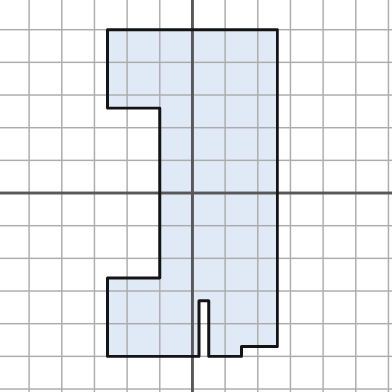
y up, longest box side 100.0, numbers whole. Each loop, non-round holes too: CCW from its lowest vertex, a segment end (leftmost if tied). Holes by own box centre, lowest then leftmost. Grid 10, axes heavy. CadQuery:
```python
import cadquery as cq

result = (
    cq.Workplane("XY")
    .moveTo(-26.0, -50.0)
    .lineTo(2.0, -50.0)
    .lineTo(2.0, -33.0)
    .lineTo(5.0, -33.0)
    .lineTo(5.0, -50.0)
    .lineTo(15.0, -50.0)
    .lineTo(15.0, -47.0)
    .lineTo(26.0, -47.0)
    .lineTo(26.0, 50.0)
    .lineTo(-26.0, 50.0)
    .lineTo(-26.0, 26.0)
    .lineTo(-10.0, 26.0)
    .lineTo(-10.0, -26.0)
    .lineTo(-26.0, -26.0)
    .close()
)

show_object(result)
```